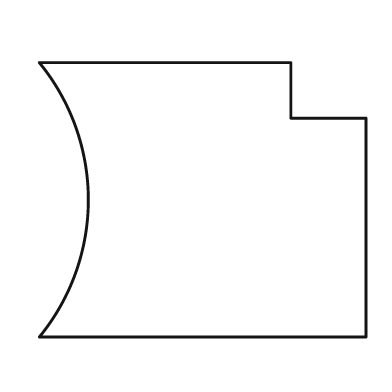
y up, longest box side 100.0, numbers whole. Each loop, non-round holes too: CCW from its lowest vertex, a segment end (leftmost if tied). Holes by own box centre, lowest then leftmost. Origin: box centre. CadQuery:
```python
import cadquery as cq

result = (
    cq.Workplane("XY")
    .moveTo(-50.0, -42.0)
    .lineTo(50.0, -42.0)
    .lineTo(50.0, 25.0)
    .lineTo(27.0, 25.0)
    .lineTo(27.0, 42.0)
    .lineTo(-50.0, 42.0)
    .threePointArc((-35.0, 0.0), (-50.0, -42.0))
    .close()
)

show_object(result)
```